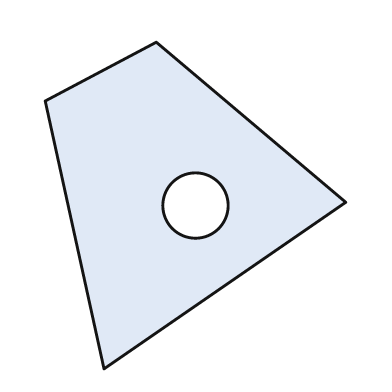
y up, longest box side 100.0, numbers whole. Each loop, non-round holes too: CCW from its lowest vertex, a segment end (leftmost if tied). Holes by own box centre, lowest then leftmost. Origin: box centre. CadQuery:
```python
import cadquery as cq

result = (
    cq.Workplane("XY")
    .moveTo(-28.0, -50.0)
    .lineTo(46.0, 1.0)
    .lineTo(-12.0, 50.0)
    .lineTo(-46.0, 32.0)
    .close()
    .moveTo(0.0, 0.0)
    .circle(10.0)
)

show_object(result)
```